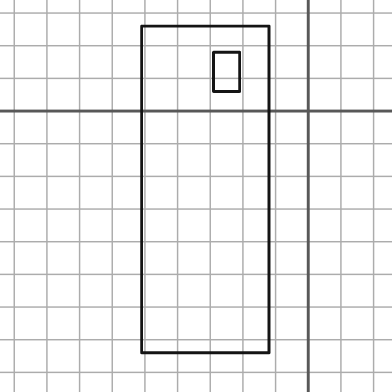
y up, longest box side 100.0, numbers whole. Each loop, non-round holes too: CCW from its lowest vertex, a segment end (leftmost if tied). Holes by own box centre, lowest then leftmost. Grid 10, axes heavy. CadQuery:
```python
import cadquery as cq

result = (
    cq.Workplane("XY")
    .moveTo(-51.0, -74.0)
    .lineTo(-12.0, -74.0)
    .lineTo(-12.0, 26.0)
    .lineTo(-51.0, 26.0)
    .close()
    .moveTo(-29.0, 6.0)
    .lineTo(-21.0, 6.0)
    .lineTo(-21.0, 18.0)
    .lineTo(-29.0, 18.0)
    .close()
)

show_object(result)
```